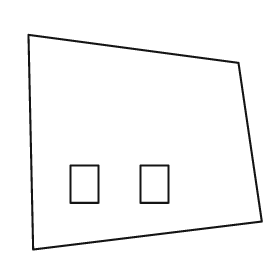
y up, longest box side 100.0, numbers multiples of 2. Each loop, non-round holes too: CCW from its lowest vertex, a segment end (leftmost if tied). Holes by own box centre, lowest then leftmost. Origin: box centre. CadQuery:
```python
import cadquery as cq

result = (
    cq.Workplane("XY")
    .moveTo(-48.0, -46.0)
    .lineTo(50.0, -34.0)
    .lineTo(40.0, 34.0)
    .lineTo(-50.0, 46.0)
    .close()
    .moveTo(-32.0, -26.0)
    .lineTo(-20.0, -26.0)
    .lineTo(-20.0, -10.0)
    .lineTo(-32.0, -10.0)
    .close()
    .moveTo(-2.0, -26.0)
    .lineTo(10.0, -26.0)
    .lineTo(10.0, -10.0)
    .lineTo(-2.0, -10.0)
    .close()
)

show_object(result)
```